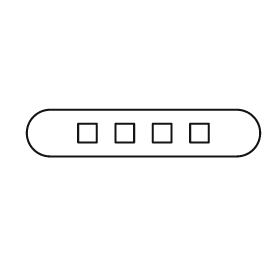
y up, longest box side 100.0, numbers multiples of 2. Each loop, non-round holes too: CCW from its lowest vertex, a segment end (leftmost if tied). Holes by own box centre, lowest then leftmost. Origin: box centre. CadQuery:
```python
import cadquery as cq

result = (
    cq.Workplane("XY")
    .moveTo(-40.0, -10.0)
    .lineTo(40.0, -10.0)
    .threePointArc((50.0, 0.0), (40.0, 10.0))
    .lineTo(-40.0, 10.0)
    .threePointArc((-50.0, 0.0), (-40.0, -10.0))
    .close()
    .moveTo(-28.0, -4.0)
    .lineTo(-20.0, -4.0)
    .lineTo(-20.0, 4.0)
    .lineTo(-28.0, 4.0)
    .close()
    .moveTo(-12.0, -4.0)
    .lineTo(-4.0, -4.0)
    .lineTo(-4.0, 4.0)
    .lineTo(-12.0, 4.0)
    .close()
    .moveTo(4.0, -4.0)
    .lineTo(12.0, -4.0)
    .lineTo(12.0, 4.0)
    .lineTo(4.0, 4.0)
    .close()
    .moveTo(20.0, -4.0)
    .lineTo(28.0, -4.0)
    .lineTo(28.0, 4.0)
    .lineTo(20.0, 4.0)
    .close()
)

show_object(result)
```